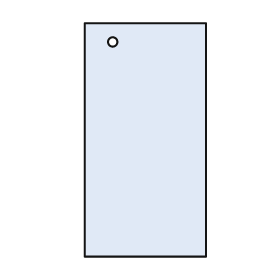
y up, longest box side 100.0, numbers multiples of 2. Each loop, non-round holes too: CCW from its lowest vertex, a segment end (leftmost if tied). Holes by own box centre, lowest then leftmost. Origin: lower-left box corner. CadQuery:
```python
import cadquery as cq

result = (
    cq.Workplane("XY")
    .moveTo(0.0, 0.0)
    .lineTo(52.0, 0.0)
    .lineTo(52.0, 100.0)
    .lineTo(0.0, 100.0)
    .close()
    .moveTo(12.0, 92.0)
    .circle(2.0)
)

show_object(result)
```